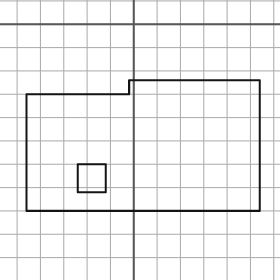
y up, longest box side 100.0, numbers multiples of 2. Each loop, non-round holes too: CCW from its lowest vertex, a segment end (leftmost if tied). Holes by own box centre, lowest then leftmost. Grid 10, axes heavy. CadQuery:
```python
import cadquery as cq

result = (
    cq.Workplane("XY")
    .moveTo(-46.0, -80.0)
    .lineTo(54.0, -80.0)
    .lineTo(54.0, -24.0)
    .lineTo(-2.0, -24.0)
    .lineTo(-2.0, -30.0)
    .lineTo(-46.0, -30.0)
    .close()
    .moveTo(-24.0, -72.0)
    .lineTo(-12.0, -72.0)
    .lineTo(-12.0, -60.0)
    .lineTo(-24.0, -60.0)
    .close()
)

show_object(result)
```